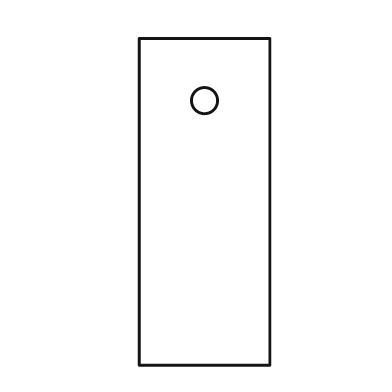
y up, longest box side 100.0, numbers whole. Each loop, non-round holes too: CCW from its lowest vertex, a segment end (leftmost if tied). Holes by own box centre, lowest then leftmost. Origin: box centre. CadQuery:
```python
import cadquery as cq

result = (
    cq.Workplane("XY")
    .moveTo(-20.0, -50.0)
    .lineTo(20.0, -50.0)
    .lineTo(20.0, 50.0)
    .lineTo(-20.0, 50.0)
    .close()
    .moveTo(0.0, 31.0)
    .circle(4.0)
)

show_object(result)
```